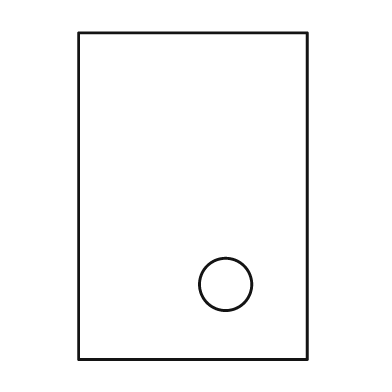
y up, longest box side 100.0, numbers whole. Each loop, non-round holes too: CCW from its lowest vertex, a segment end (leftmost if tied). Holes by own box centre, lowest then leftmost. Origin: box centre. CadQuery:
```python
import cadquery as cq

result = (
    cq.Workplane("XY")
    .moveTo(-35.0, -50.0)
    .lineTo(35.0, -50.0)
    .lineTo(35.0, 50.0)
    .lineTo(-35.0, 50.0)
    .close()
    .moveTo(10.0, -27.0)
    .circle(8.0)
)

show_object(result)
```